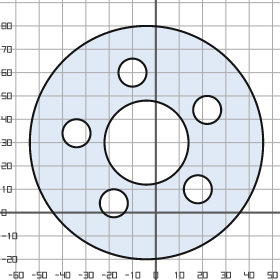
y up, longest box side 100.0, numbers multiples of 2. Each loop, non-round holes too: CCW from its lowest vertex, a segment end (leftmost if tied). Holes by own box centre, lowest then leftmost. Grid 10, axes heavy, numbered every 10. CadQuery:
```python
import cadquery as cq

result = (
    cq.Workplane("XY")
    .moveTo(-4.0, 30.0)
    .circle(50.0)
    .moveTo(-18.0, 4.0)
    .circle(6.0)
    .moveTo(18.0, 10.0)
    .circle(6.0)
    .moveTo(-4.0, 30.0)
    .circle(18.0)
    .moveTo(-34.0, 34.0)
    .circle(6.0)
    .moveTo(22.0, 44.0)
    .circle(6.0)
    .moveTo(-10.0, 60.0)
    .circle(6.0)
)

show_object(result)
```